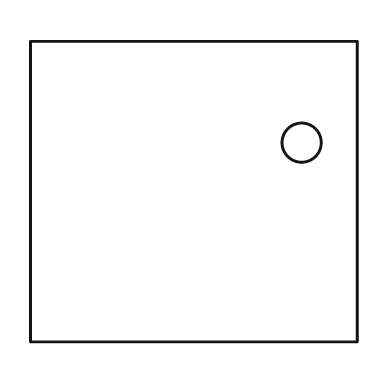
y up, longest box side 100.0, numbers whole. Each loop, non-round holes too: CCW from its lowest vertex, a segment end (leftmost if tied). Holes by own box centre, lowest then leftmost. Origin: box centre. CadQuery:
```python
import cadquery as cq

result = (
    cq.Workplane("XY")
    .moveTo(-50.0, -46.0)
    .lineTo(50.0, -46.0)
    .lineTo(50.0, 46.0)
    .lineTo(-50.0, 46.0)
    .close()
    .moveTo(33.0, 15.0)
    .circle(6.0)
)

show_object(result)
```